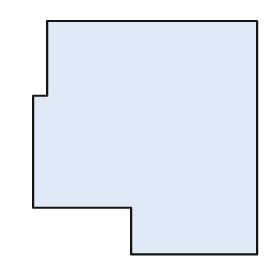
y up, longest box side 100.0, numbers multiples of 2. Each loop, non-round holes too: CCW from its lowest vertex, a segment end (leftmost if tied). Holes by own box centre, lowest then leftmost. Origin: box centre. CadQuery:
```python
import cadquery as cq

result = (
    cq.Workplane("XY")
    .moveTo(-6.0, -50.0)
    .lineTo(48.0, -50.0)
    .lineTo(48.0, 50.0)
    .lineTo(-42.0, 50.0)
    .lineTo(-42.0, 18.0)
    .lineTo(-48.0, 18.0)
    .lineTo(-48.0, -30.0)
    .lineTo(-6.0, -30.0)
    .close()
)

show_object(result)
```